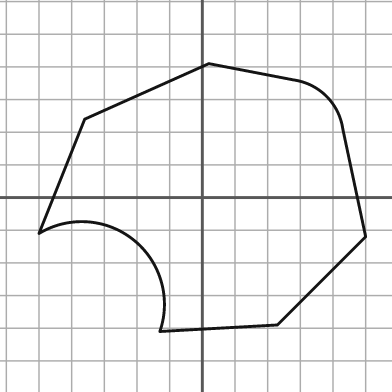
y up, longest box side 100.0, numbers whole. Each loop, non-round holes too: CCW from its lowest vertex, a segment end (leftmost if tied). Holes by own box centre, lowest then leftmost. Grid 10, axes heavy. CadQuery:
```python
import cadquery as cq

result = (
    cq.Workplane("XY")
    .moveTo(-13.0, -41.0)
    .lineTo(23.0, -39.0)
    .lineTo(50.0, -12.0)
    .lineTo(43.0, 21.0)
    .threePointArc((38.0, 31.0), (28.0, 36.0))
    .lineTo(2.0, 41.0)
    .lineTo(-36.0, 24.0)
    .lineTo(-50.0, -11.0)
    .threePointArc((-21.0, -13.0), (-13.0, -41.0))
    .close()
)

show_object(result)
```